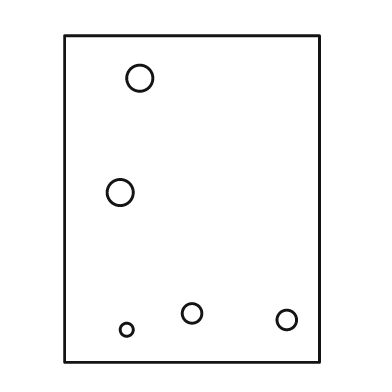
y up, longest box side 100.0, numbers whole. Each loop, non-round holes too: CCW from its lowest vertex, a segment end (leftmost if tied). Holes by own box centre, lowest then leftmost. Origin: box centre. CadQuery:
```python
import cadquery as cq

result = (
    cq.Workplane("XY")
    .moveTo(-39.0, -50.0)
    .lineTo(39.0, -50.0)
    .lineTo(39.0, 50.0)
    .lineTo(-39.0, 50.0)
    .close()
    .moveTo(-20.0, -40.0)
    .circle(2.0)
    .moveTo(29.0, -37.0)
    .circle(3.0)
    .moveTo(0.0, -35.0)
    .circle(3.0)
    .moveTo(-22.0, 2.0)
    .circle(4.0)
    .moveTo(-16.0, 37.0)
    .circle(4.0)
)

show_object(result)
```